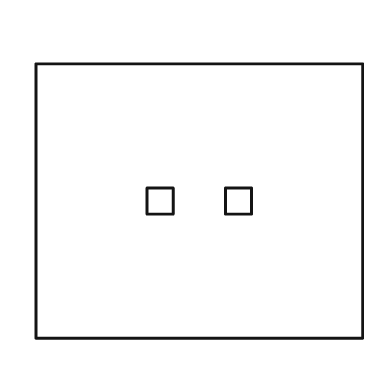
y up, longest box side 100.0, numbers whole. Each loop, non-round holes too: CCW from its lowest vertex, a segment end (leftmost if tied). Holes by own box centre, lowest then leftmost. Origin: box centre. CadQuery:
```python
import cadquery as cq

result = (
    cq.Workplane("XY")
    .moveTo(-50.0, -42.0)
    .lineTo(50.0, -42.0)
    .lineTo(50.0, 42.0)
    .lineTo(-50.0, 42.0)
    .close()
    .moveTo(-16.0, -4.0)
    .lineTo(-8.0, -4.0)
    .lineTo(-8.0, 4.0)
    .lineTo(-16.0, 4.0)
    .close()
    .moveTo(8.0, -4.0)
    .lineTo(16.0, -4.0)
    .lineTo(16.0, 4.0)
    .lineTo(8.0, 4.0)
    .close()
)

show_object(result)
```